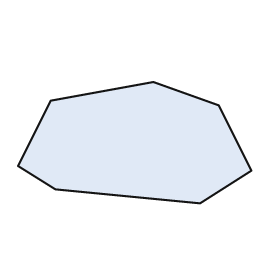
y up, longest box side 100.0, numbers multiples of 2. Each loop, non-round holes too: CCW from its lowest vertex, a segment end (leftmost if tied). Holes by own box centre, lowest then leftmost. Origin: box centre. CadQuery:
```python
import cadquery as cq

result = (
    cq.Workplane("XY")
    .moveTo(28.0, -26.0)
    .lineTo(50.0, -12.0)
    .lineTo(36.0, 16.0)
    .lineTo(8.0, 26.0)
    .lineTo(-36.0, 18.0)
    .lineTo(-50.0, -10.0)
    .lineTo(-34.0, -20.0)
    .close()
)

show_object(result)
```